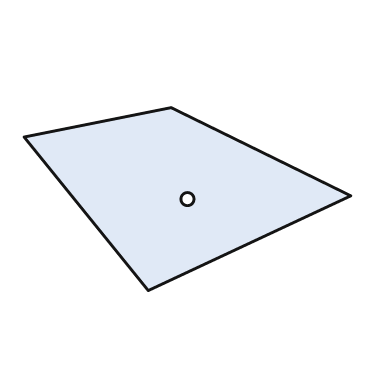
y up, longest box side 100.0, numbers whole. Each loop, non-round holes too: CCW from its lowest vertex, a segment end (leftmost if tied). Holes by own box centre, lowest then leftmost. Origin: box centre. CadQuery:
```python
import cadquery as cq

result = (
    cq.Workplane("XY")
    .moveTo(-12.0, -28.0)
    .lineTo(50.0, 1.0)
    .lineTo(-5.0, 28.0)
    .lineTo(-50.0, 19.0)
    .close()
    .moveTo(0.0, 0.0)
    .circle(2.0)
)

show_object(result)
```